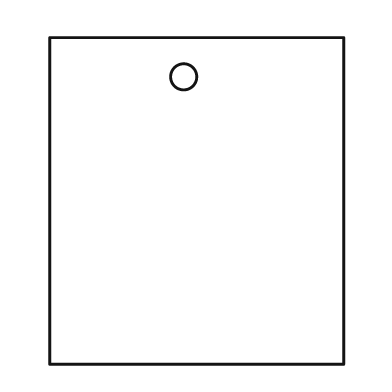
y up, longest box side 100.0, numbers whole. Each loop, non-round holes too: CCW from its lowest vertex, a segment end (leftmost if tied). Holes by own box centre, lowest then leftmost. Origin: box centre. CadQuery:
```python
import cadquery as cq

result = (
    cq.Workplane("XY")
    .moveTo(-45.0, -50.0)
    .lineTo(45.0, -50.0)
    .lineTo(45.0, 50.0)
    .lineTo(-45.0, 50.0)
    .close()
    .moveTo(-4.0, 38.0)
    .circle(4.0)
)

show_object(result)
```